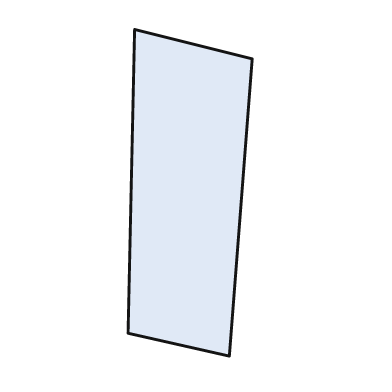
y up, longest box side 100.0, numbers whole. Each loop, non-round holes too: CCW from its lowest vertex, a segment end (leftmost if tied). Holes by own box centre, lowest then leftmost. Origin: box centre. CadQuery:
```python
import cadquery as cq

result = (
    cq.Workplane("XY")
    .moveTo(12.0, -50.0)
    .lineTo(19.0, 41.0)
    .lineTo(-17.0, 50.0)
    .lineTo(-19.0, -43.0)
    .close()
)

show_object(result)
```